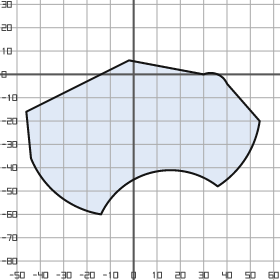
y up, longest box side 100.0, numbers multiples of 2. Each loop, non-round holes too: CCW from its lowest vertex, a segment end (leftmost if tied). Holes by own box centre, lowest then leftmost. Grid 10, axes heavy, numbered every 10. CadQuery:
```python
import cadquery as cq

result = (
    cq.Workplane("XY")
    .moveTo(-14.0, -60.0)
    .threePointArc((8.0, -42.0), (36.0, -48.0))
    .threePointArc((48.0, -36.0), (54.0, -20.0))
    .lineTo(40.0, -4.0)
    .threePointArc((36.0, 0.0), (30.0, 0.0))
    .lineTo(-2.0, 6.0)
    .lineTo(-46.0, -16.0)
    .lineTo(-44.0, -36.0)
    .threePointArc((-32.0, -52.0), (-14.0, -60.0))
    .close()
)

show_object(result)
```